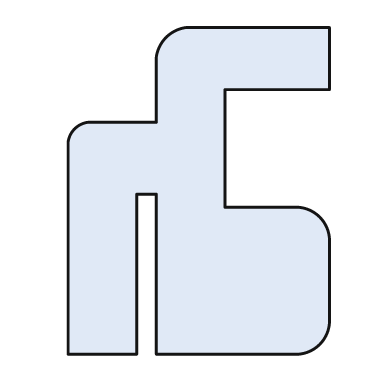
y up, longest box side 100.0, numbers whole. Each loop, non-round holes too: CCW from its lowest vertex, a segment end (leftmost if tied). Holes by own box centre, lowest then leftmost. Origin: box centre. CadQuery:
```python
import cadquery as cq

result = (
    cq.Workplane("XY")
    .moveTo(-40.0, -50.0)
    .lineTo(-19.0, -50.0)
    .lineTo(-19.0, -1.0)
    .lineTo(-13.0, -1.0)
    .lineTo(-13.0, -50.0)
    .lineTo(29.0, -50.0)
    .threePointArc((37.0, -47.0), (40.0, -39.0))
    .lineTo(40.0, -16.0)
    .threePointArc((37.0, -8.0), (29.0, -5.0))
    .lineTo(8.0, -5.0)
    .lineTo(8.0, 31.0)
    .lineTo(40.0, 31.0)
    .lineTo(40.0, 50.0)
    .lineTo(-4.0, 50.0)
    .threePointArc((-10.0, 47.0), (-13.0, 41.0))
    .lineTo(-13.0, 21.0)
    .lineTo(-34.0, 21.0)
    .threePointArc((-38.0, 19.0), (-40.0, 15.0))
    .close()
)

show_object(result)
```